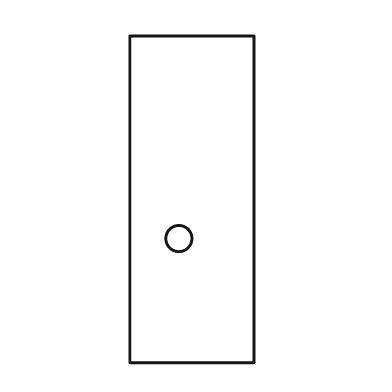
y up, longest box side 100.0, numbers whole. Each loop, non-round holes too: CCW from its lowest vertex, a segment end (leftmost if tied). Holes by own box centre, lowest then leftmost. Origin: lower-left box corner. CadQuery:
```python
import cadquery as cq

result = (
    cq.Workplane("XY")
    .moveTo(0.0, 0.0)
    .lineTo(38.0, 0.0)
    .lineTo(38.0, 100.0)
    .lineTo(0.0, 100.0)
    .close()
    .moveTo(15.0, 38.0)
    .circle(4.0)
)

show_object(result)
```